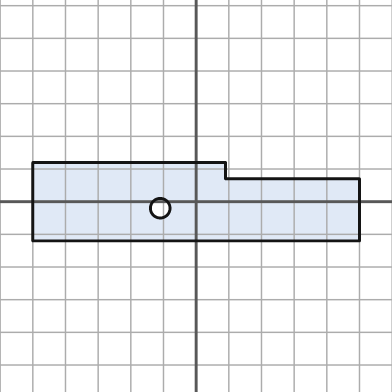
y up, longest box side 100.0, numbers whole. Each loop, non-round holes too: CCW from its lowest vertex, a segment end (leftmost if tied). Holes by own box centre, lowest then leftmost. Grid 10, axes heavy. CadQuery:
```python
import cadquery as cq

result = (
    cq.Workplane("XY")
    .moveTo(-50.0, -12.0)
    .lineTo(50.0, -12.0)
    .lineTo(50.0, 7.0)
    .lineTo(9.0, 7.0)
    .lineTo(9.0, 12.0)
    .lineTo(-50.0, 12.0)
    .close()
    .moveTo(-11.0, -2.0)
    .circle(3.0)
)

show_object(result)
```